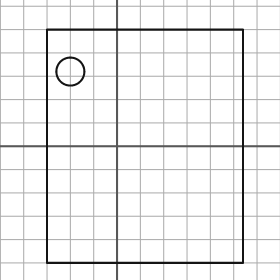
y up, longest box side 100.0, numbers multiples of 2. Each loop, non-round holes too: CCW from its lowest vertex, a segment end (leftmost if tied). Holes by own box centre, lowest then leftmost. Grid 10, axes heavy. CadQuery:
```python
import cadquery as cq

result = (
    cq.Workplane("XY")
    .moveTo(-30.0, -50.0)
    .lineTo(54.0, -50.0)
    .lineTo(54.0, 50.0)
    .lineTo(-30.0, 50.0)
    .close()
    .moveTo(-20.0, 32.0)
    .circle(6.0)
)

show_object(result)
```